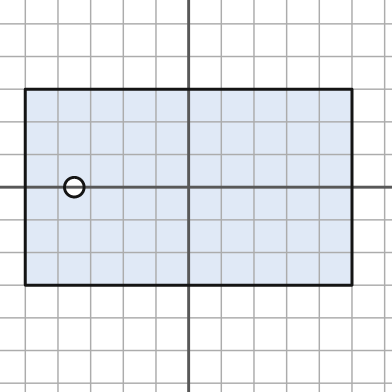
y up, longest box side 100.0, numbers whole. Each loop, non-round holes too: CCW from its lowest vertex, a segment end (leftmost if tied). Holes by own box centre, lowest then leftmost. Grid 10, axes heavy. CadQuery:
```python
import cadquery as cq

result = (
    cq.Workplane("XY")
    .moveTo(-50.0, -30.0)
    .lineTo(50.0, -30.0)
    .lineTo(50.0, 30.0)
    .lineTo(-50.0, 30.0)
    .close()
    .moveTo(-35.0, 0.0)
    .circle(3.0)
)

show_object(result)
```